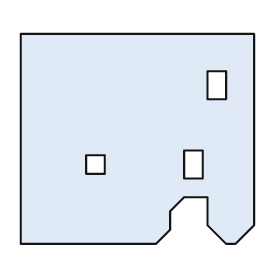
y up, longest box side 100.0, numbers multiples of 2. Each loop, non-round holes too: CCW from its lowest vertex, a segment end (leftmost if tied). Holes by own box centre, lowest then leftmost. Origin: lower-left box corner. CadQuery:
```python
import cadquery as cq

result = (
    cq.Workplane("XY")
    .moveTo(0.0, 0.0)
    .lineTo(58.0, 0.0)
    .lineTo(64.0, 6.0)
    .lineTo(64.0, 14.0)
    .lineTo(70.0, 20.0)
    .lineTo(80.0, 20.0)
    .lineTo(80.0, 8.0)
    .lineTo(88.0, 0.0)
    .lineTo(92.0, 0.0)
    .lineTo(100.0, 8.0)
    .lineTo(100.0, 90.0)
    .lineTo(0.0, 90.0)
    .close()
    .moveTo(28.0, 30.0)
    .lineTo(36.0, 30.0)
    .lineTo(36.0, 38.0)
    .lineTo(28.0, 38.0)
    .close()
    .moveTo(70.0, 28.0)
    .lineTo(78.0, 28.0)
    .lineTo(78.0, 40.0)
    .lineTo(70.0, 40.0)
    .close()
    .moveTo(80.0, 62.0)
    .lineTo(88.0, 62.0)
    .lineTo(88.0, 74.0)
    .lineTo(80.0, 74.0)
    .close()
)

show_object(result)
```